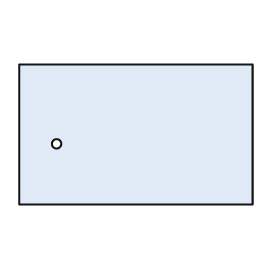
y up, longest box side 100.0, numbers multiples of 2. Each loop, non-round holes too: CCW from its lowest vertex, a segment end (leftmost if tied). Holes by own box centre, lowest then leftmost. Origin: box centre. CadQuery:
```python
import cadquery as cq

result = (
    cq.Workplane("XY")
    .moveTo(-50.0, -30.0)
    .lineTo(50.0, -30.0)
    .lineTo(50.0, 30.0)
    .lineTo(-50.0, 30.0)
    .close()
    .moveTo(-34.0, -4.0)
    .circle(2.0)
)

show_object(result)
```